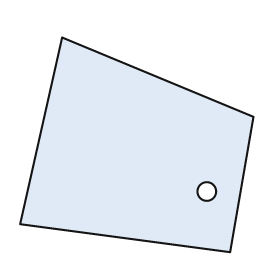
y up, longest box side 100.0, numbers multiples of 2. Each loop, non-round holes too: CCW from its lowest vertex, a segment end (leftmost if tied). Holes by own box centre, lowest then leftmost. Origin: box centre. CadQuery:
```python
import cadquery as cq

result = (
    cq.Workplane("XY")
    .moveTo(40.0, -46.0)
    .lineTo(50.0, 12.0)
    .lineTo(-32.0, 46.0)
    .lineTo(-50.0, -34.0)
    .close()
    .moveTo(30.0, -20.0)
    .circle(4.0)
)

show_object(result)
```